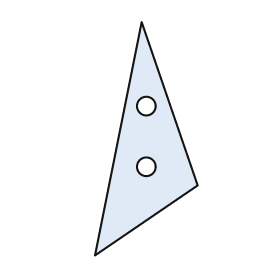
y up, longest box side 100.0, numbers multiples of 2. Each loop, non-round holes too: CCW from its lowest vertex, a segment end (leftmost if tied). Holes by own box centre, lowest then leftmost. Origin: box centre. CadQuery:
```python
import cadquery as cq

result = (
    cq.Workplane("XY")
    .moveTo(-22.0, -50.0)
    .lineTo(22.0, -20.0)
    .lineTo(-2.0, 50.0)
    .close()
    .moveTo(0.0, -12.0)
    .circle(4.0)
    .moveTo(0.0, 14.0)
    .circle(4.0)
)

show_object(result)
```